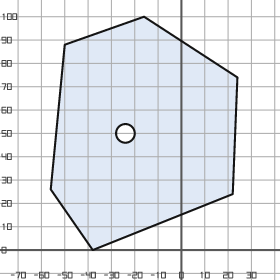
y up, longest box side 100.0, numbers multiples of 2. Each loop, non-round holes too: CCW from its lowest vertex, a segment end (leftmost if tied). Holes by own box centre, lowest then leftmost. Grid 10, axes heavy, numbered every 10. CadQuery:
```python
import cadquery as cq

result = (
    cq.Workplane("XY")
    .moveTo(-38.0, 0.0)
    .lineTo(22.0, 24.0)
    .lineTo(24.0, 74.0)
    .lineTo(-16.0, 100.0)
    .lineTo(-50.0, 88.0)
    .lineTo(-56.0, 26.0)
    .close()
    .moveTo(-24.0, 50.0)
    .circle(4.0)
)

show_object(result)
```